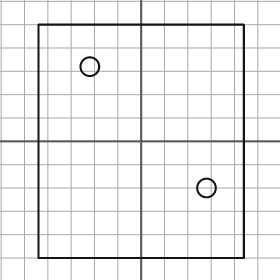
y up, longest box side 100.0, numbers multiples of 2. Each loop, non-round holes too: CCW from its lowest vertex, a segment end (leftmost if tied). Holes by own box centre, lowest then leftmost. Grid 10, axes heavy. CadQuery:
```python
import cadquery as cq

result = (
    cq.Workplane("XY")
    .moveTo(-44.0, -50.0)
    .lineTo(44.0, -50.0)
    .lineTo(44.0, 50.0)
    .lineTo(-44.0, 50.0)
    .close()
    .moveTo(28.0, -20.0)
    .circle(4.0)
    .moveTo(-22.0, 32.0)
    .circle(4.0)
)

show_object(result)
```